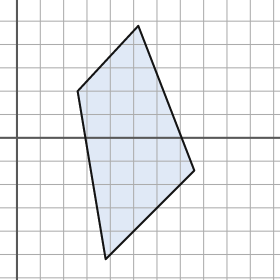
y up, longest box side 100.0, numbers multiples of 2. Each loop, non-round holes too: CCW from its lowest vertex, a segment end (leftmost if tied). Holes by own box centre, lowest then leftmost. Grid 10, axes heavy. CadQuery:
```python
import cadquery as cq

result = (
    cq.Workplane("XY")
    .moveTo(38.0, -52.0)
    .lineTo(76.0, -14.0)
    .lineTo(52.0, 48.0)
    .lineTo(26.0, 20.0)
    .close()
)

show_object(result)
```